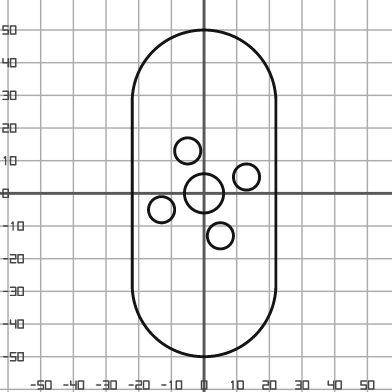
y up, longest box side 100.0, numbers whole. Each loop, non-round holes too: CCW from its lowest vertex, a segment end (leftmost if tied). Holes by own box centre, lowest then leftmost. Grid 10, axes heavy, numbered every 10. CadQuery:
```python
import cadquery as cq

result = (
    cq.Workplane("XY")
    .moveTo(-22.0, -28.0)
    .threePointArc((0.0, -50.0), (22.0, -28.0))
    .lineTo(22.0, 28.0)
    .threePointArc((0.0, 50.0), (-22.0, 28.0))
    .close()
    .moveTo(5.0, -13.0)
    .circle(4.0)
    .moveTo(-13.0, -5.0)
    .circle(4.0)
    .moveTo(0.0, 0.0)
    .circle(6.0)
    .moveTo(13.0, 5.0)
    .circle(4.0)
    .moveTo(-5.0, 13.0)
    .circle(4.0)
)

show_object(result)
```